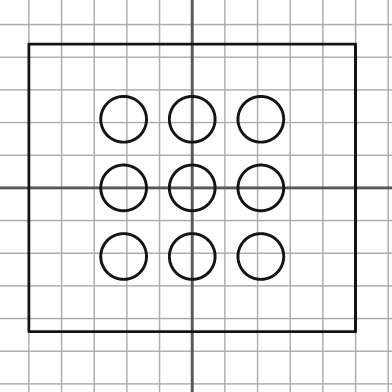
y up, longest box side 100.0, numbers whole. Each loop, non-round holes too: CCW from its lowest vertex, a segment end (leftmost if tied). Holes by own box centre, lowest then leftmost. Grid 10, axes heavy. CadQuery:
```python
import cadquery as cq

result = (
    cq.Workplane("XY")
    .moveTo(-50.0, -44.0)
    .lineTo(50.0, -44.0)
    .lineTo(50.0, 44.0)
    .lineTo(-50.0, 44.0)
    .close()
    .moveTo(-21.0, -21.0)
    .circle(7.0)
    .moveTo(0.0, -21.0)
    .circle(7.0)
    .moveTo(21.0, -21.0)
    .circle(7.0)
    .moveTo(-21.0, 0.0)
    .circle(7.0)
    .moveTo(0.0, 0.0)
    .circle(7.0)
    .moveTo(21.0, 0.0)
    .circle(7.0)
    .moveTo(-21.0, 21.0)
    .circle(7.0)
    .moveTo(0.0, 21.0)
    .circle(7.0)
    .moveTo(21.0, 21.0)
    .circle(7.0)
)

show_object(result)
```